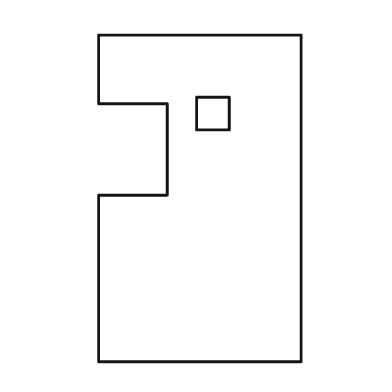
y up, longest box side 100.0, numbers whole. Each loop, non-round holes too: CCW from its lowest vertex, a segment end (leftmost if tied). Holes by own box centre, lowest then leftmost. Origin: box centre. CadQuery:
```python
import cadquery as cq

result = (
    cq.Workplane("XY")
    .moveTo(-31.0, -50.0)
    .lineTo(31.0, -50.0)
    .lineTo(31.0, 50.0)
    .lineTo(-31.0, 50.0)
    .lineTo(-31.0, 29.0)
    .lineTo(-10.0, 29.0)
    .lineTo(-10.0, 1.0)
    .lineTo(-31.0, 1.0)
    .close()
    .moveTo(-1.0, 21.0)
    .lineTo(9.0, 21.0)
    .lineTo(9.0, 31.0)
    .lineTo(-1.0, 31.0)
    .close()
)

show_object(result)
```